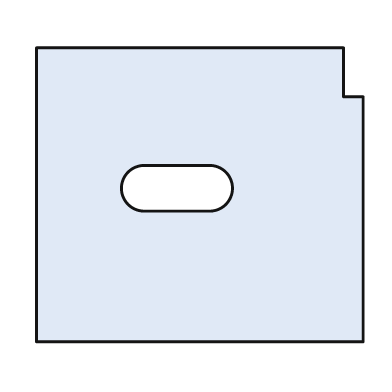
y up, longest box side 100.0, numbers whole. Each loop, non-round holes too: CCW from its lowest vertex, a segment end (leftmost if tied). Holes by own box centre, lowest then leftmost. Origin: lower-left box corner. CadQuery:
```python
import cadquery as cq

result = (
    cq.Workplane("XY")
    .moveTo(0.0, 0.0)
    .lineTo(100.0, 0.0)
    .lineTo(100.0, 75.0)
    .lineTo(94.0, 75.0)
    .lineTo(94.0, 90.0)
    .lineTo(0.0, 90.0)
    .close()
    .moveTo(33.0, 40.0)
    .lineTo(53.0, 40.0)
    .threePointArc((60.0, 47.0), (53.0, 54.0))
    .lineTo(33.0, 54.0)
    .threePointArc((26.0, 47.0), (33.0, 40.0))
    .close()
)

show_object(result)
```